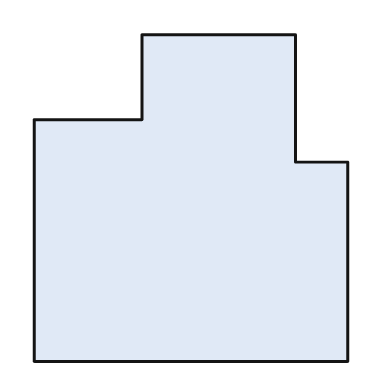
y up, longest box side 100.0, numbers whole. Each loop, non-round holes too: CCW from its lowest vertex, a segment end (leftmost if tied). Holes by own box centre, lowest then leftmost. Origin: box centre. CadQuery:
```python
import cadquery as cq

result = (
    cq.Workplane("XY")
    .moveTo(-48.0, -50.0)
    .lineTo(48.0, -50.0)
    .lineTo(48.0, 11.0)
    .lineTo(32.0, 11.0)
    .lineTo(32.0, 50.0)
    .lineTo(-15.0, 50.0)
    .lineTo(-15.0, 24.0)
    .lineTo(-48.0, 24.0)
    .close()
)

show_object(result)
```